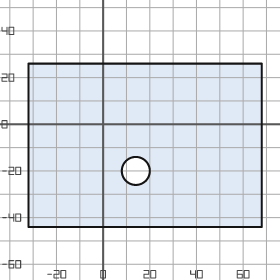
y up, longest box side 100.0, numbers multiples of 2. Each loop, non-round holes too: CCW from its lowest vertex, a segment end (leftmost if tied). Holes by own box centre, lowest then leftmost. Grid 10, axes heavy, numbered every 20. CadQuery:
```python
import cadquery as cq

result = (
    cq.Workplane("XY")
    .moveTo(-32.0, -44.0)
    .lineTo(68.0, -44.0)
    .lineTo(68.0, 26.0)
    .lineTo(-32.0, 26.0)
    .close()
    .moveTo(14.0, -20.0)
    .circle(6.0)
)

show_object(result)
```